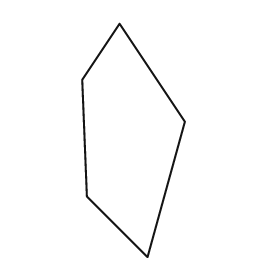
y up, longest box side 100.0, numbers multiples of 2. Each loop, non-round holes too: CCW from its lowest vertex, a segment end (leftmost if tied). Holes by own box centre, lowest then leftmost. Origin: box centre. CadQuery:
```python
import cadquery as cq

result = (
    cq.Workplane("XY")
    .moveTo(6.0, -50.0)
    .lineTo(22.0, 8.0)
    .lineTo(-6.0, 50.0)
    .lineTo(-22.0, 26.0)
    .lineTo(-20.0, -24.0)
    .close()
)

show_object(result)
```